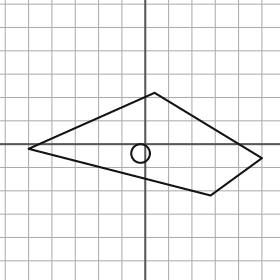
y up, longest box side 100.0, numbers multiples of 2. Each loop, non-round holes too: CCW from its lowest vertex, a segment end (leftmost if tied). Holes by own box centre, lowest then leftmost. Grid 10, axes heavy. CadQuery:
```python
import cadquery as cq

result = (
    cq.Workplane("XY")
    .moveTo(28.0, -22.0)
    .lineTo(50.0, -6.0)
    .lineTo(4.0, 22.0)
    .lineTo(-50.0, -2.0)
    .close()
    .moveTo(-2.0, -4.0)
    .circle(4.0)
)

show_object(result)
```